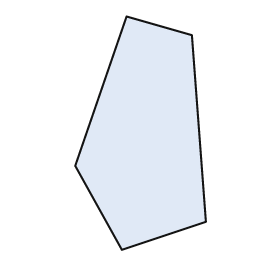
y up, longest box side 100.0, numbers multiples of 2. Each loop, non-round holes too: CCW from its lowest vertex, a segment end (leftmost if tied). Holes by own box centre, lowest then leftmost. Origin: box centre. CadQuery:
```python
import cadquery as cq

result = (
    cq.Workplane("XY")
    .moveTo(-8.0, -50.0)
    .lineTo(28.0, -38.0)
    .lineTo(22.0, 42.0)
    .lineTo(-6.0, 50.0)
    .lineTo(-28.0, -14.0)
    .close()
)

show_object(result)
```